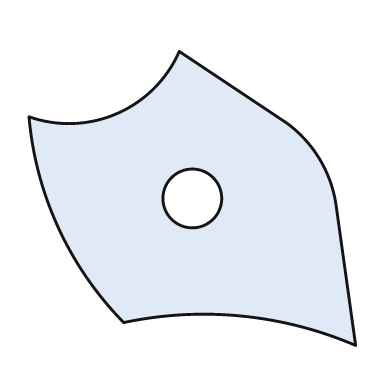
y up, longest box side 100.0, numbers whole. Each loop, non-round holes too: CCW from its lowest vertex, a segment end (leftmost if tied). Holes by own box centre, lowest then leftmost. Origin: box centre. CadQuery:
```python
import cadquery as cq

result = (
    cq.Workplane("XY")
    .moveTo(50.0, -45.0)
    .lineTo(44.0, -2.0)
    .threePointArc((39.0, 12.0), (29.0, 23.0))
    .lineTo(-4.0, 45.0)
    .threePointArc((-23.0, 26.0), (-50.0, 25.0))
    .threePointArc((-41.0, -9.0), (-21.0, -38.0))
    .threePointArc((15.0, -36.0), (50.0, -45.0))
    .close()
    .moveTo(0.0, 0.0)
    .circle(9.0)
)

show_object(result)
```